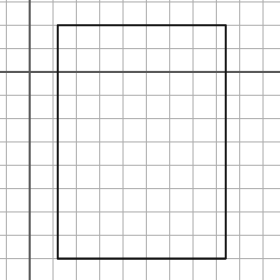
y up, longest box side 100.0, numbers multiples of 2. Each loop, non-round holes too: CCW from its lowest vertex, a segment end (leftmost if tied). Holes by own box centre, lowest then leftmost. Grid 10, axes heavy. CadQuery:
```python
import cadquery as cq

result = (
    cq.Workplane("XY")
    .moveTo(12.0, -80.0)
    .lineTo(84.0, -80.0)
    .lineTo(84.0, 20.0)
    .lineTo(12.0, 20.0)
    .close()
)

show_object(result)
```